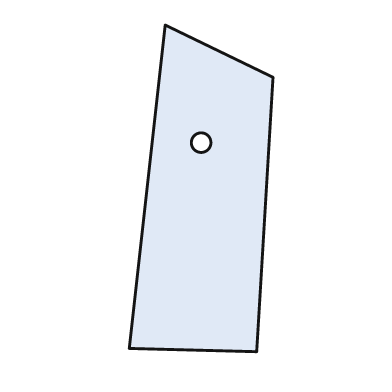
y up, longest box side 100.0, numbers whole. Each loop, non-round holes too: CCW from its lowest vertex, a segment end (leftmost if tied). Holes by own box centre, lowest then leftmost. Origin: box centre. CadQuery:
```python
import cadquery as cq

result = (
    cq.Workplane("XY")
    .moveTo(17.0, -50.0)
    .lineTo(22.0, 34.0)
    .lineTo(-11.0, 50.0)
    .lineTo(-22.0, -49.0)
    .close()
    .moveTo(0.0, 14.0)
    .circle(3.0)
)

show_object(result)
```